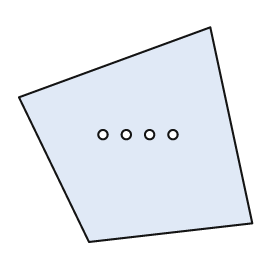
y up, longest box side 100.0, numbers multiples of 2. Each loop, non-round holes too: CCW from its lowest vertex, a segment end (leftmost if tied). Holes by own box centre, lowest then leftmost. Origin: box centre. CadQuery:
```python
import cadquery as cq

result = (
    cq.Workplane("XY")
    .moveTo(-20.0, -46.0)
    .lineTo(50.0, -38.0)
    .lineTo(32.0, 46.0)
    .lineTo(-50.0, 16.0)
    .close()
    .moveTo(-14.0, 0.0)
    .circle(2.0)
    .moveTo(-4.0, 0.0)
    .circle(2.0)
    .moveTo(6.0, 0.0)
    .circle(2.0)
    .moveTo(16.0, 0.0)
    .circle(2.0)
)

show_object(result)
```